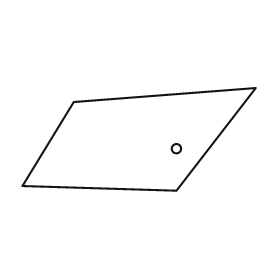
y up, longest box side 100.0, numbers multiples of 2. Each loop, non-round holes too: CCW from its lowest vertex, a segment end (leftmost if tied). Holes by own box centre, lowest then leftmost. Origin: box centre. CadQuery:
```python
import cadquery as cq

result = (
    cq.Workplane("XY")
    .moveTo(16.0, -22.0)
    .lineTo(50.0, 22.0)
    .lineTo(-28.0, 16.0)
    .lineTo(-50.0, -20.0)
    .close()
    .moveTo(16.0, -4.0)
    .circle(2.0)
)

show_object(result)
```